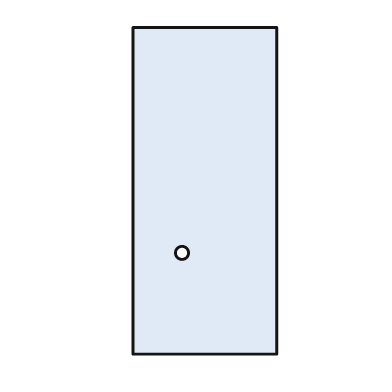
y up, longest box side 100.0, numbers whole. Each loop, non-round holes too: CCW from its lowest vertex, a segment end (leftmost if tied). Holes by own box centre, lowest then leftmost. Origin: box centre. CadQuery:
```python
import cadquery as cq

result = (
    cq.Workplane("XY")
    .moveTo(-22.0, -50.0)
    .lineTo(22.0, -50.0)
    .lineTo(22.0, 50.0)
    .lineTo(-22.0, 50.0)
    .close()
    .moveTo(-7.0, -19.0)
    .circle(2.0)
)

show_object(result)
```